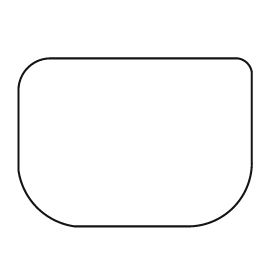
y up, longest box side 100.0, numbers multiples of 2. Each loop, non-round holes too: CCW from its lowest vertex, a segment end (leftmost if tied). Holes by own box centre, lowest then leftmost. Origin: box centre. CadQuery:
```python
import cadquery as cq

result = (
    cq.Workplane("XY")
    .moveTo(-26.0, -36.0)
    .lineTo(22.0, -36.0)
    .threePointArc((42.0, -28.0), (50.0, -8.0))
    .lineTo(50.0, 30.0)
    .threePointArc((48.0, 34.0), (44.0, 36.0))
    .lineTo(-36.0, 36.0)
    .threePointArc((-46.0, 32.0), (-50.0, 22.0))
    .lineTo(-50.0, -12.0)
    .threePointArc((-42.0, -28.0), (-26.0, -36.0))
    .close()
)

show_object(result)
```